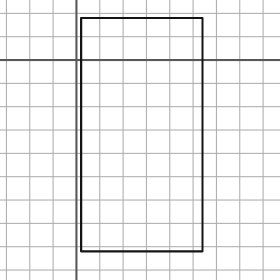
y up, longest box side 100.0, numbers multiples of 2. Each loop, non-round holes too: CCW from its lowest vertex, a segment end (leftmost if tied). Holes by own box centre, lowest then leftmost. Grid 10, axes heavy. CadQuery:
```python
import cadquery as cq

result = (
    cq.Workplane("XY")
    .moveTo(2.0, -82.0)
    .lineTo(54.0, -82.0)
    .lineTo(54.0, 18.0)
    .lineTo(2.0, 18.0)
    .close()
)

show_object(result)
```